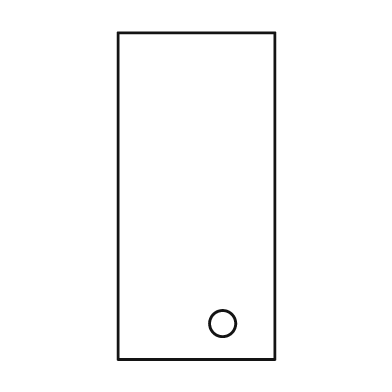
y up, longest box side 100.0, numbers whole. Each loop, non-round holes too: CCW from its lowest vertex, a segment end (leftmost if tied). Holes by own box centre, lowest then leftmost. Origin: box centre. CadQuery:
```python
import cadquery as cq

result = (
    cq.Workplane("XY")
    .moveTo(-24.0, -50.0)
    .lineTo(24.0, -50.0)
    .lineTo(24.0, 50.0)
    .lineTo(-24.0, 50.0)
    .close()
    .moveTo(8.0, -39.0)
    .circle(4.0)
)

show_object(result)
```